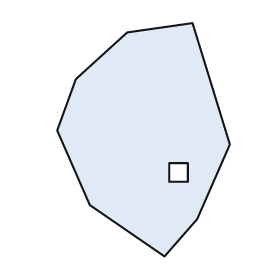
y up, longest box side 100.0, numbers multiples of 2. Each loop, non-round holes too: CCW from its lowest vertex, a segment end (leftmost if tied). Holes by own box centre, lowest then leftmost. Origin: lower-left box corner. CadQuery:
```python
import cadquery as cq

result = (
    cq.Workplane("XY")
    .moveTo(46.0, 0.0)
    .lineTo(60.0, 16.0)
    .lineTo(74.0, 48.0)
    .lineTo(58.0, 100.0)
    .lineTo(30.0, 96.0)
    .lineTo(8.0, 76.0)
    .lineTo(0.0, 54.0)
    .lineTo(14.0, 22.0)
    .close()
    .moveTo(48.0, 32.0)
    .lineTo(56.0, 32.0)
    .lineTo(56.0, 40.0)
    .lineTo(48.0, 40.0)
    .close()
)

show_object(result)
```